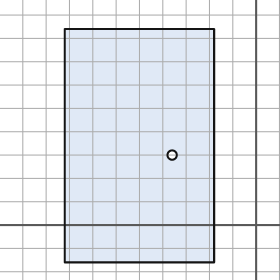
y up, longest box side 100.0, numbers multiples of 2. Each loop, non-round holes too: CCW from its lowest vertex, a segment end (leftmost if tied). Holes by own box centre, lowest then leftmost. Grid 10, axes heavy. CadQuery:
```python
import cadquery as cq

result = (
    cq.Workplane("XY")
    .moveTo(-82.0, -16.0)
    .lineTo(-18.0, -16.0)
    .lineTo(-18.0, 84.0)
    .lineTo(-82.0, 84.0)
    .close()
    .moveTo(-36.0, 30.0)
    .circle(2.0)
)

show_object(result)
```